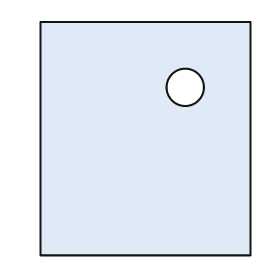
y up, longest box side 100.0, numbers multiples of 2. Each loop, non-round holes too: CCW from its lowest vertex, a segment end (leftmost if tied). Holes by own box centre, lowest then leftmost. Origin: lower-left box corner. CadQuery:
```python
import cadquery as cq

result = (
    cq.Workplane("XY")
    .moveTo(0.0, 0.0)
    .lineTo(90.0, 0.0)
    .lineTo(90.0, 100.0)
    .lineTo(0.0, 100.0)
    .close()
    .moveTo(62.0, 72.0)
    .circle(8.0)
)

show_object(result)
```